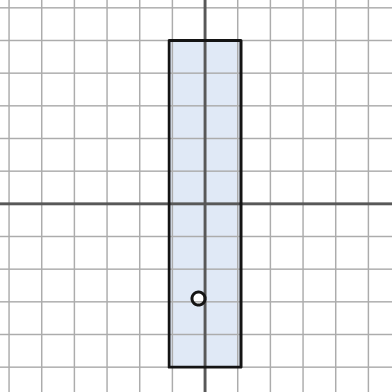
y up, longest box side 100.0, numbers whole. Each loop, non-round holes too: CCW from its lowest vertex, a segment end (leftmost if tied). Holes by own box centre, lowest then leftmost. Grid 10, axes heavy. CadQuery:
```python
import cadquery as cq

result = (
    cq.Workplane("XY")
    .moveTo(-11.0, -50.0)
    .lineTo(11.0, -50.0)
    .lineTo(11.0, 50.0)
    .lineTo(-11.0, 50.0)
    .close()
    .moveTo(-2.0, -29.0)
    .circle(2.0)
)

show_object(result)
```